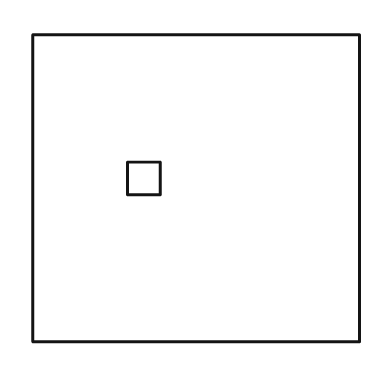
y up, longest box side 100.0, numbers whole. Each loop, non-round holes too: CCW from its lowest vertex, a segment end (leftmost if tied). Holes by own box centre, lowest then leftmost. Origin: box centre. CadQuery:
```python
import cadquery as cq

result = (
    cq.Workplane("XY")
    .moveTo(-50.0, -47.0)
    .lineTo(50.0, -47.0)
    .lineTo(50.0, 47.0)
    .lineTo(-50.0, 47.0)
    .close()
    .moveTo(-21.0, -2.0)
    .lineTo(-11.0, -2.0)
    .lineTo(-11.0, 8.0)
    .lineTo(-21.0, 8.0)
    .close()
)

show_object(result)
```